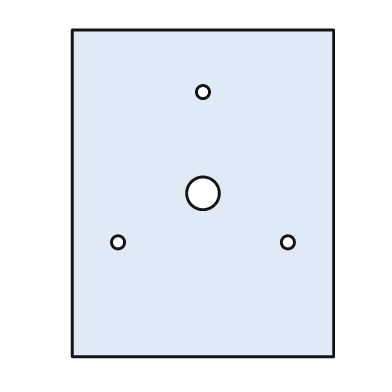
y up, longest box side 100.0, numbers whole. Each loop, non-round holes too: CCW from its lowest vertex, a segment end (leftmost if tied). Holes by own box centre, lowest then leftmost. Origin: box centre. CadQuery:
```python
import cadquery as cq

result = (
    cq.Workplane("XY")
    .moveTo(-40.0, -50.0)
    .lineTo(40.0, -50.0)
    .lineTo(40.0, 50.0)
    .lineTo(-40.0, 50.0)
    .close()
    .moveTo(-26.0, -15.0)
    .circle(2.0)
    .moveTo(26.0, -15.0)
    .circle(2.0)
    .moveTo(0.0, 0.0)
    .circle(5.0)
    .moveTo(0.0, 31.0)
    .circle(2.0)
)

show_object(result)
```